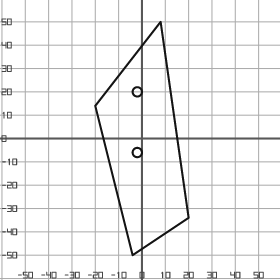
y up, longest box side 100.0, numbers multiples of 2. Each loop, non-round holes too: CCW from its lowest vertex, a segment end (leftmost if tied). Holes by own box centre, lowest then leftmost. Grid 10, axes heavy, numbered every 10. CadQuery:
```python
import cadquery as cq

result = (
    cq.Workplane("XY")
    .moveTo(-4.0, -50.0)
    .lineTo(20.0, -34.0)
    .lineTo(8.0, 50.0)
    .lineTo(-20.0, 14.0)
    .close()
    .moveTo(-2.0, -6.0)
    .circle(2.0)
    .moveTo(-2.0, 20.0)
    .circle(2.0)
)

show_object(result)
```